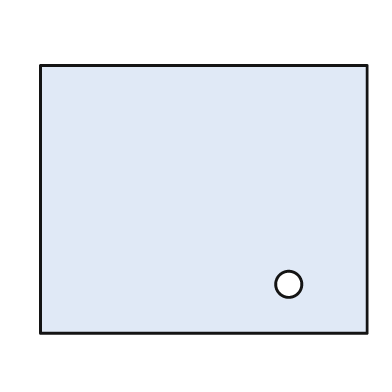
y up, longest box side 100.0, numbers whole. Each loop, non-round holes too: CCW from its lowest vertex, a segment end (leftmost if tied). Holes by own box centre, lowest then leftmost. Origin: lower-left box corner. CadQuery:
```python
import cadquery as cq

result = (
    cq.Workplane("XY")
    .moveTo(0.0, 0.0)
    .lineTo(100.0, 0.0)
    .lineTo(100.0, 82.0)
    .lineTo(0.0, 82.0)
    .close()
    .moveTo(76.0, 15.0)
    .circle(4.0)
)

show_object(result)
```